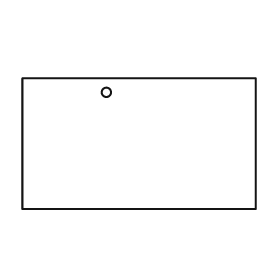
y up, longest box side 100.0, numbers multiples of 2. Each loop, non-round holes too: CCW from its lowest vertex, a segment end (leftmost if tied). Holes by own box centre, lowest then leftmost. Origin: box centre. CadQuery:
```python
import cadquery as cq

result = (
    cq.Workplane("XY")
    .moveTo(-50.0, -28.0)
    .lineTo(50.0, -28.0)
    .lineTo(50.0, 28.0)
    .lineTo(-50.0, 28.0)
    .close()
    .moveTo(-14.0, 22.0)
    .circle(2.0)
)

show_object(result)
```